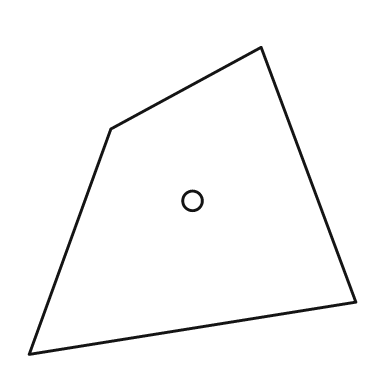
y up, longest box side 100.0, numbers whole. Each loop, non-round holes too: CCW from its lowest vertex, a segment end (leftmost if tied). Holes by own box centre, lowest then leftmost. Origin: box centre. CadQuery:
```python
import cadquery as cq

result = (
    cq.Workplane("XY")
    .moveTo(-50.0, -47.0)
    .lineTo(50.0, -31.0)
    .lineTo(21.0, 47.0)
    .lineTo(-25.0, 22.0)
    .close()
    .moveTo(0.0, 0.0)
    .circle(3.0)
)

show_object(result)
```